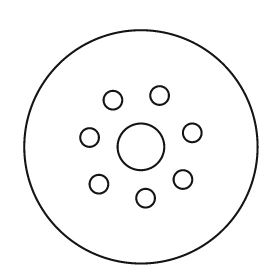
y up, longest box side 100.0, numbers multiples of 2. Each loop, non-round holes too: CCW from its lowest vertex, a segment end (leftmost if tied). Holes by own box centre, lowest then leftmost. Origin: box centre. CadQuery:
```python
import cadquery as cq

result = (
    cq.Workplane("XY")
    .moveTo(0.0, 0.0)
    .circle(50.0)
    .moveTo(2.0, -22.0)
    .circle(4.0)
    .moveTo(-18.0, -16.0)
    .circle(4.0)
    .moveTo(18.0, -14.0)
    .circle(4.0)
    .moveTo(0.0, 0.0)
    .circle(10.0)
    .moveTo(-22.0, 4.0)
    .circle(4.0)
    .moveTo(22.0, 6.0)
    .circle(4.0)
    .moveTo(-12.0, 20.0)
    .circle(4.0)
    .moveTo(8.0, 22.0)
    .circle(4.0)
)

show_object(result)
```